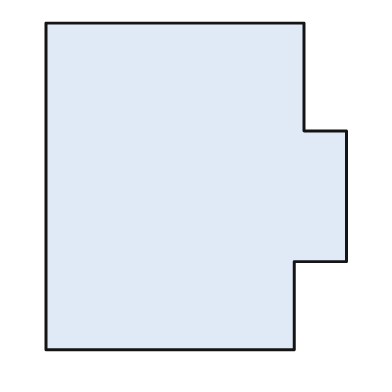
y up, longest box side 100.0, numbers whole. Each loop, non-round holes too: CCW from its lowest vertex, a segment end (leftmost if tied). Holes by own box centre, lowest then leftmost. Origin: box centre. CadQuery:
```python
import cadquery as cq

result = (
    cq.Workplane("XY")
    .moveTo(-46.0, -50.0)
    .lineTo(30.0, -50.0)
    .lineTo(30.0, -23.0)
    .lineTo(46.0, -23.0)
    .lineTo(46.0, 17.0)
    .lineTo(33.0, 17.0)
    .lineTo(33.0, 50.0)
    .lineTo(-46.0, 50.0)
    .close()
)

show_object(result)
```